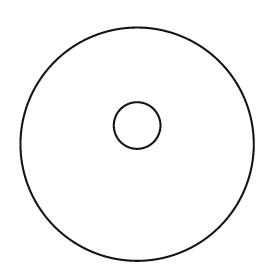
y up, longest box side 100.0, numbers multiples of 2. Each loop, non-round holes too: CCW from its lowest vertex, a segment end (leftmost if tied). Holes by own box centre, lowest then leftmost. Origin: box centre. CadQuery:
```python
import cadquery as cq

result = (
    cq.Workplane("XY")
    .moveTo(0.0, 0.0)
    .circle(50.0)
    .moveTo(0.0, 8.0)
    .circle(10.0)
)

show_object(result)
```